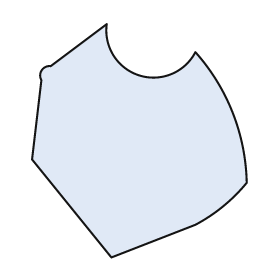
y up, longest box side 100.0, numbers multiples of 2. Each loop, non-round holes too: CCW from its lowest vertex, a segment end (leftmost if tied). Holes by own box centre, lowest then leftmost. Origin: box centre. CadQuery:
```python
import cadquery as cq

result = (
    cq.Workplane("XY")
    .moveTo(-12.0, -50.0)
    .lineTo(24.0, -36.0)
    .threePointArc((36.0, -28.0), (46.0, -18.0))
    .threePointArc((40.0, 12.0), (24.0, 38.0))
    .threePointArc((0.0, 28.0), (-14.0, 50.0))
    .lineTo(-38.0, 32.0)
    .threePointArc((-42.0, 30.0), (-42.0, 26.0))
    .lineTo(-46.0, -8.0)
    .close()
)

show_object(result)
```